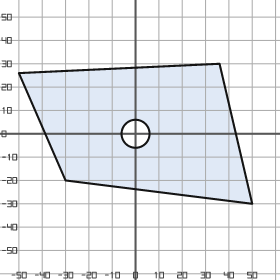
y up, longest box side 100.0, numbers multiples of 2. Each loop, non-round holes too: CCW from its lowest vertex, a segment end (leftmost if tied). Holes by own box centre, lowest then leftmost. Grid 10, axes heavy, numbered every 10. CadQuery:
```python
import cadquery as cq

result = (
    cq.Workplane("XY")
    .moveTo(50.0, -30.0)
    .lineTo(36.0, 30.0)
    .lineTo(-50.0, 26.0)
    .lineTo(-30.0, -20.0)
    .close()
    .moveTo(0.0, 0.0)
    .circle(6.0)
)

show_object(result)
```